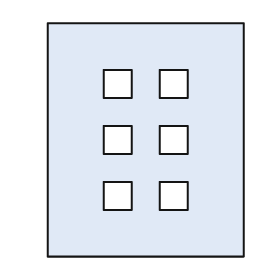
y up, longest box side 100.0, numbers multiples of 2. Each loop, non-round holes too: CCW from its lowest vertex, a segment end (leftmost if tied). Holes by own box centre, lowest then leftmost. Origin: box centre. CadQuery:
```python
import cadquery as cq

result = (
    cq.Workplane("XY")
    .moveTo(-42.0, -50.0)
    .lineTo(42.0, -50.0)
    .lineTo(42.0, 50.0)
    .lineTo(-42.0, 50.0)
    .close()
    .moveTo(-18.0, -30.0)
    .lineTo(-6.0, -30.0)
    .lineTo(-6.0, -18.0)
    .lineTo(-18.0, -18.0)
    .close()
    .moveTo(6.0, -30.0)
    .lineTo(18.0, -30.0)
    .lineTo(18.0, -18.0)
    .lineTo(6.0, -18.0)
    .close()
    .moveTo(-18.0, -6.0)
    .lineTo(-6.0, -6.0)
    .lineTo(-6.0, 6.0)
    .lineTo(-18.0, 6.0)
    .close()
    .moveTo(6.0, -6.0)
    .lineTo(18.0, -6.0)
    .lineTo(18.0, 6.0)
    .lineTo(6.0, 6.0)
    .close()
    .moveTo(-18.0, 18.0)
    .lineTo(-6.0, 18.0)
    .lineTo(-6.0, 30.0)
    .lineTo(-18.0, 30.0)
    .close()
    .moveTo(6.0, 18.0)
    .lineTo(18.0, 18.0)
    .lineTo(18.0, 30.0)
    .lineTo(6.0, 30.0)
    .close()
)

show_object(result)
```